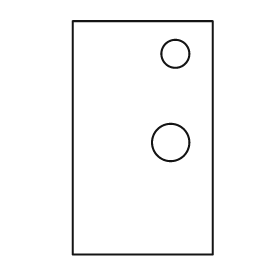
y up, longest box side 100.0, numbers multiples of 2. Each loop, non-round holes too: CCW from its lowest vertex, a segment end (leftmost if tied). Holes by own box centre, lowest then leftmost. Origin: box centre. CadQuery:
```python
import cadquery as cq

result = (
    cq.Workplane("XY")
    .moveTo(-30.0, -50.0)
    .lineTo(30.0, -50.0)
    .lineTo(30.0, 50.0)
    .lineTo(-30.0, 50.0)
    .close()
    .moveTo(12.0, -2.0)
    .circle(8.0)
    .moveTo(14.0, 36.0)
    .circle(6.0)
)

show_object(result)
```